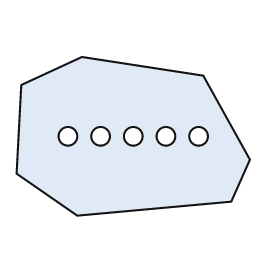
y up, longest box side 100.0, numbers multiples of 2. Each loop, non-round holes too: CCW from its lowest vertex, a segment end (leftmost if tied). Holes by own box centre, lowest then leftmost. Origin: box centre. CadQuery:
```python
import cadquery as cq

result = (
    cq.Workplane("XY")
    .moveTo(-24.0, -34.0)
    .lineTo(42.0, -28.0)
    .lineTo(50.0, -10.0)
    .lineTo(30.0, 26.0)
    .lineTo(-22.0, 34.0)
    .lineTo(-48.0, 22.0)
    .lineTo(-50.0, -16.0)
    .close()
    .moveTo(-28.0, 0.0)
    .circle(4.0)
    .moveTo(-14.0, 0.0)
    .circle(4.0)
    .moveTo(0.0, 0.0)
    .circle(4.0)
    .moveTo(14.0, 0.0)
    .circle(4.0)
    .moveTo(28.0, 0.0)
    .circle(4.0)
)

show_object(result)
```